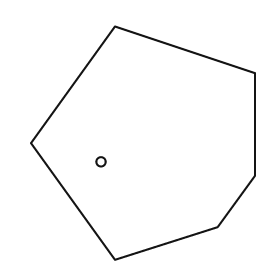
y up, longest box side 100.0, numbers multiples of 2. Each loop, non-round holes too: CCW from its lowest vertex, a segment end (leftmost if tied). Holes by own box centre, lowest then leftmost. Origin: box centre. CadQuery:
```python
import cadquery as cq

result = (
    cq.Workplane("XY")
    .moveTo(-12.0, -50.0)
    .lineTo(32.0, -36.0)
    .lineTo(48.0, -14.0)
    .lineTo(48.0, 30.0)
    .lineTo(-12.0, 50.0)
    .lineTo(-48.0, 0.0)
    .close()
    .moveTo(-18.0, -8.0)
    .circle(2.0)
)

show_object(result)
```